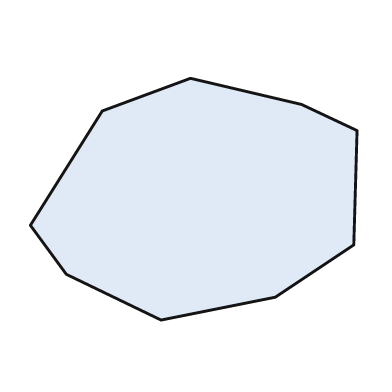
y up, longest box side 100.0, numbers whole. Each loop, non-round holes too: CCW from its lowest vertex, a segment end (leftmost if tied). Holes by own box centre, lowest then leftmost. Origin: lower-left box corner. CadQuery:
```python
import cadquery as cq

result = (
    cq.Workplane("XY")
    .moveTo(40.0, 0.0)
    .lineTo(75.0, 7.0)
    .lineTo(99.0, 23.0)
    .lineTo(100.0, 58.0)
    .lineTo(83.0, 66.0)
    .lineTo(49.0, 74.0)
    .lineTo(22.0, 64.0)
    .lineTo(0.0, 29.0)
    .lineTo(11.0, 14.0)
    .close()
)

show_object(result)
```